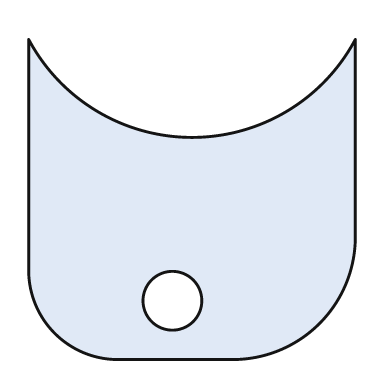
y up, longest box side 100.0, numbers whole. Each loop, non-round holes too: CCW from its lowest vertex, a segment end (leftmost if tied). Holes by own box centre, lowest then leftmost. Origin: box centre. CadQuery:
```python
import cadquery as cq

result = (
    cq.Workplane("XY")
    .moveTo(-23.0, -49.0)
    .lineTo(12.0, -49.0)
    .threePointArc((39.0, -38.0), (50.0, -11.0))
    .lineTo(50.0, 49.0)
    .threePointArc((0.0, 19.0), (-50.0, 49.0))
    .lineTo(-50.0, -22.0)
    .threePointArc((-42.0, -41.0), (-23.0, -49.0))
    .close()
    .moveTo(-6.0, -31.0)
    .circle(9.0)
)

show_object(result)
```